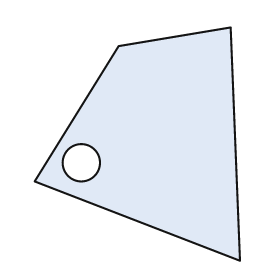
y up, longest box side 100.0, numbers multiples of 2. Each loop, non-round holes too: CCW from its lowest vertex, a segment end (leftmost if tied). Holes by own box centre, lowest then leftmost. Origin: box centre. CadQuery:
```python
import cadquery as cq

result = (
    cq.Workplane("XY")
    .moveTo(44.0, -50.0)
    .lineTo(40.0, 50.0)
    .lineTo(-8.0, 42.0)
    .lineTo(-44.0, -16.0)
    .close()
    .moveTo(-24.0, -8.0)
    .circle(8.0)
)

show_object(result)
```